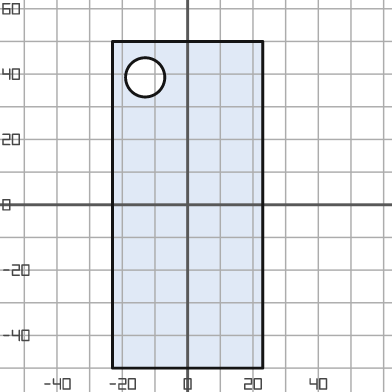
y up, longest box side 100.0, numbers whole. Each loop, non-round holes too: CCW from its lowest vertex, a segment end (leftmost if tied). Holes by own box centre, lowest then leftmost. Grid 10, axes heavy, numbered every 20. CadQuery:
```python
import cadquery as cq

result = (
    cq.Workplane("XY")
    .moveTo(-23.0, -50.0)
    .lineTo(23.0, -50.0)
    .lineTo(23.0, 50.0)
    .lineTo(-23.0, 50.0)
    .close()
    .moveTo(-13.0, 39.0)
    .circle(6.0)
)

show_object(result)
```